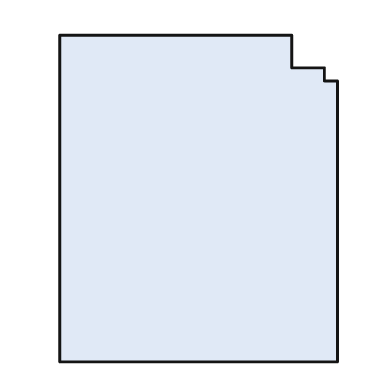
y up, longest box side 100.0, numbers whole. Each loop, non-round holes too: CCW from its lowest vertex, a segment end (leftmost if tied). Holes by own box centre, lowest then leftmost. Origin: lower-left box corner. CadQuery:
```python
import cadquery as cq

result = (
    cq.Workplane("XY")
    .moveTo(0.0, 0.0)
    .lineTo(85.0, 0.0)
    .lineTo(85.0, 86.0)
    .lineTo(81.0, 86.0)
    .lineTo(81.0, 90.0)
    .lineTo(71.0, 90.0)
    .lineTo(71.0, 100.0)
    .lineTo(0.0, 100.0)
    .close()
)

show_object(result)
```